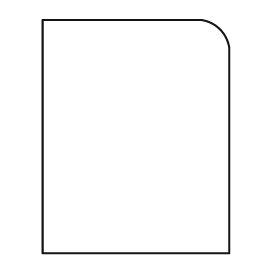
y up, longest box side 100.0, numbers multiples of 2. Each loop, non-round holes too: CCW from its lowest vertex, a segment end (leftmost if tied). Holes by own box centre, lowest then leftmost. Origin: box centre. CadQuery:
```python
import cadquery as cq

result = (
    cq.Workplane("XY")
    .moveTo(-40.0, -50.0)
    .lineTo(40.0, -50.0)
    .lineTo(40.0, 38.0)
    .threePointArc((36.0, 46.0), (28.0, 50.0))
    .lineTo(-40.0, 50.0)
    .close()
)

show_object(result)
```